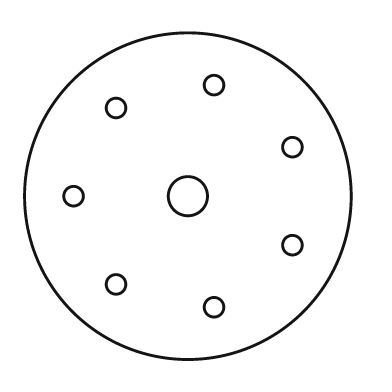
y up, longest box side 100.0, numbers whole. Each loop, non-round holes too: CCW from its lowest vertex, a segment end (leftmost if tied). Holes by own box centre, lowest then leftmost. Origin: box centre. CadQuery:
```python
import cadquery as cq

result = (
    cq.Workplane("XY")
    .moveTo(0.0, 0.0)
    .circle(50.0)
    .moveTo(8.0, -34.0)
    .circle(3.0)
    .moveTo(-22.0, -27.0)
    .circle(3.0)
    .moveTo(32.0, -15.0)
    .circle(3.0)
    .moveTo(-35.0, 0.0)
    .circle(3.0)
    .moveTo(0.0, 0.0)
    .circle(6.0)
    .moveTo(32.0, 15.0)
    .circle(3.0)
    .moveTo(-22.0, 27.0)
    .circle(3.0)
    .moveTo(8.0, 34.0)
    .circle(3.0)
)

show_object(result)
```